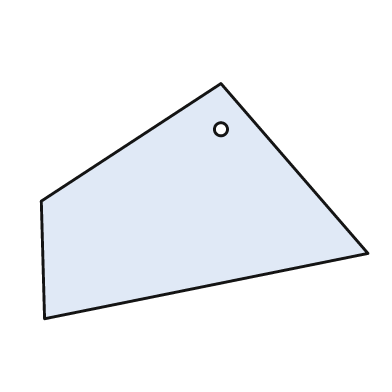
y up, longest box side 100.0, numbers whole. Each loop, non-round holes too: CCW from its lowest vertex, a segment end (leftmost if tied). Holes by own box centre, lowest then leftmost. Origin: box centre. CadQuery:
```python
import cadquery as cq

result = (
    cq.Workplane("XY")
    .moveTo(-49.0, -36.0)
    .lineTo(50.0, -16.0)
    .lineTo(5.0, 36.0)
    .lineTo(-50.0, 0.0)
    .close()
    .moveTo(5.0, 22.0)
    .circle(2.0)
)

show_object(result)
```